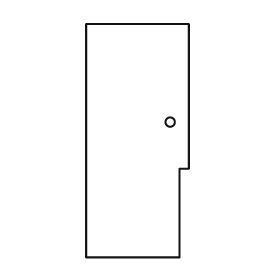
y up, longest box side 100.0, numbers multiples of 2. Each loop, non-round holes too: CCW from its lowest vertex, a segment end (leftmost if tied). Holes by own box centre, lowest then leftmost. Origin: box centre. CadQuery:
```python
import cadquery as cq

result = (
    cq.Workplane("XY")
    .moveTo(-22.0, -50.0)
    .lineTo(18.0, -50.0)
    .lineTo(18.0, -12.0)
    .lineTo(22.0, -12.0)
    .lineTo(22.0, 50.0)
    .lineTo(-22.0, 50.0)
    .close()
    .moveTo(14.0, 8.0)
    .circle(2.0)
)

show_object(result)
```